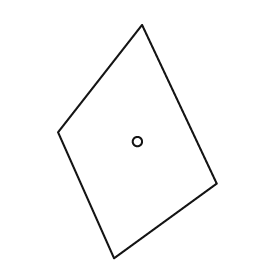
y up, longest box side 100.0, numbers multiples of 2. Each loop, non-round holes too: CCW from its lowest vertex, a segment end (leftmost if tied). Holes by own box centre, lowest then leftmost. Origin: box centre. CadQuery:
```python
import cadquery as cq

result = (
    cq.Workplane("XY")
    .moveTo(-10.0, -50.0)
    .lineTo(34.0, -18.0)
    .lineTo(2.0, 50.0)
    .lineTo(-34.0, 4.0)
    .close()
    .moveTo(0.0, 0.0)
    .circle(2.0)
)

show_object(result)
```